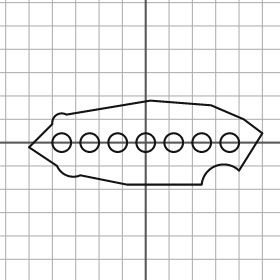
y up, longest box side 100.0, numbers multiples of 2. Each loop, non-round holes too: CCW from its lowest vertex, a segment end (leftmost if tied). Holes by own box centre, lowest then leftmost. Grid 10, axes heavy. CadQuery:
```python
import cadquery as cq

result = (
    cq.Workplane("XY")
    .moveTo(-8.0, -18.0)
    .lineTo(24.0, -18.0)
    .threePointArc((30.0, -10.0), (40.0, -12.0))
    .lineTo(50.0, 4.0)
    .lineTo(42.0, 10.0)
    .lineTo(28.0, 16.0)
    .lineTo(2.0, 18.0)
    .lineTo(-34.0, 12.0)
    .threePointArc((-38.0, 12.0), (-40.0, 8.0))
    .lineTo(-50.0, -2.0)
    .lineTo(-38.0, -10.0)
    .threePointArc((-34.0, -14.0), (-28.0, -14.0))
    .close()
    .moveTo(-36.0, 0.0)
    .circle(4.0)
    .moveTo(-24.0, 0.0)
    .circle(4.0)
    .moveTo(-12.0, 0.0)
    .circle(4.0)
    .moveTo(0.0, 0.0)
    .circle(4.0)
    .moveTo(12.0, 0.0)
    .circle(4.0)
    .moveTo(24.0, 0.0)
    .circle(4.0)
    .moveTo(36.0, 0.0)
    .circle(4.0)
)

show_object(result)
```